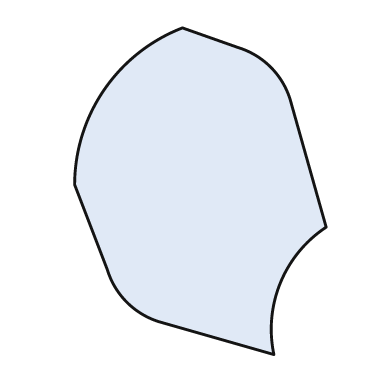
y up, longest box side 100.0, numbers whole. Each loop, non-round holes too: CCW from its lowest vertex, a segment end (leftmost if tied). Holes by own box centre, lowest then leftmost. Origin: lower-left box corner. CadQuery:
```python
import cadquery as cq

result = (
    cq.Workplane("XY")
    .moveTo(61.0, 0.0)
    .threePointArc((63.0, 22.0), (77.0, 39.0))
    .lineTo(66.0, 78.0)
    .threePointArc((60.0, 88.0), (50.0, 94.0))
    .lineTo(33.0, 100.0)
    .threePointArc((9.0, 81.0), (0.0, 52.0))
    .lineTo(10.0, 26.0)
    .threePointArc((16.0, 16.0), (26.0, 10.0))
    .close()
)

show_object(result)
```